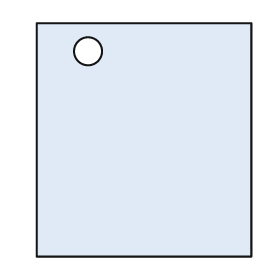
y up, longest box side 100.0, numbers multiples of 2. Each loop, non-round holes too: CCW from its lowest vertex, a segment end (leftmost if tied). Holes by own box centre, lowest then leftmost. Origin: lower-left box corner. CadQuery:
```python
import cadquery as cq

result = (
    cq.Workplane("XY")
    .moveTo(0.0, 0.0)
    .lineTo(92.0, 0.0)
    .lineTo(92.0, 100.0)
    .lineTo(0.0, 100.0)
    .close()
    .moveTo(22.0, 88.0)
    .circle(6.0)
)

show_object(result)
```